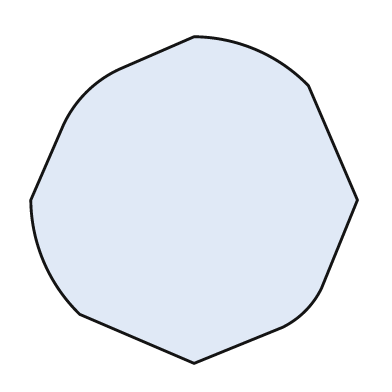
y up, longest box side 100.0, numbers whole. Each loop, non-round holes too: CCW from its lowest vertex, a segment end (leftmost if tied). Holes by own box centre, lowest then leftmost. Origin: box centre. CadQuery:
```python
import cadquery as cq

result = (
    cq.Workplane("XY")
    .moveTo(0.0, -50.0)
    .lineTo(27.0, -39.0)
    .threePointArc((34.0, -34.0), (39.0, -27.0))
    .lineTo(50.0, 0.0)
    .lineTo(35.0, 35.0)
    .threePointArc((19.0, 46.0), (0.0, 50.0))
    .lineTo(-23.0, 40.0)
    .threePointArc((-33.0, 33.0), (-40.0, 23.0))
    .lineTo(-50.0, 0.0)
    .threePointArc((-46.0, -19.0), (-35.0, -35.0))
    .close()
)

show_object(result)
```